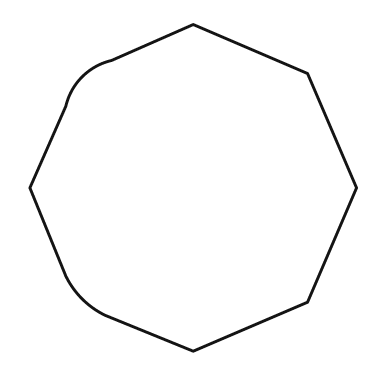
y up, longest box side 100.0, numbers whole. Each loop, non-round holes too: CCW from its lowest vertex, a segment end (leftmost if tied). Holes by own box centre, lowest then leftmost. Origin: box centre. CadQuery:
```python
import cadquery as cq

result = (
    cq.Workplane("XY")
    .moveTo(0.0, -50.0)
    .lineTo(35.0, -35.0)
    .lineTo(50.0, 0.0)
    .lineTo(35.0, 35.0)
    .lineTo(0.0, 50.0)
    .lineTo(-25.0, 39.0)
    .threePointArc((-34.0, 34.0), (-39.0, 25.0))
    .lineTo(-50.0, 0.0)
    .lineTo(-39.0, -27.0)
    .threePointArc((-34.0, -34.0), (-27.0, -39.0))
    .close()
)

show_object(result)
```